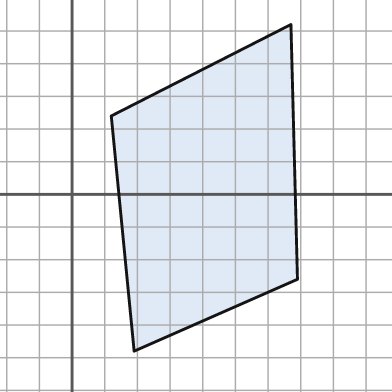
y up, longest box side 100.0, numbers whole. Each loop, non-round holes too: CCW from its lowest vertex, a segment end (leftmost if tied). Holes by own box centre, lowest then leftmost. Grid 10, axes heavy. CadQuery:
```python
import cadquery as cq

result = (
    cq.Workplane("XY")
    .moveTo(19.0, -48.0)
    .lineTo(69.0, -26.0)
    .lineTo(67.0, 52.0)
    .lineTo(12.0, 24.0)
    .close()
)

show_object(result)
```